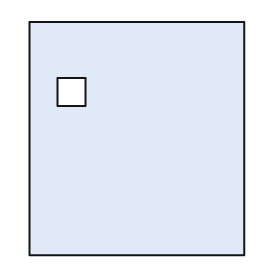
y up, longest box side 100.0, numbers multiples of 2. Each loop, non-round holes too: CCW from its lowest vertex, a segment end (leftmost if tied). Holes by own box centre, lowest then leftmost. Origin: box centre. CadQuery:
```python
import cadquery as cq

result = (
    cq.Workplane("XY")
    .moveTo(-46.0, -50.0)
    .lineTo(46.0, -50.0)
    .lineTo(46.0, 50.0)
    .lineTo(-46.0, 50.0)
    .close()
    .moveTo(-34.0, 14.0)
    .lineTo(-22.0, 14.0)
    .lineTo(-22.0, 26.0)
    .lineTo(-34.0, 26.0)
    .close()
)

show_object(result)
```